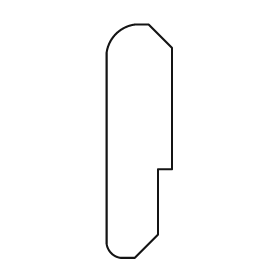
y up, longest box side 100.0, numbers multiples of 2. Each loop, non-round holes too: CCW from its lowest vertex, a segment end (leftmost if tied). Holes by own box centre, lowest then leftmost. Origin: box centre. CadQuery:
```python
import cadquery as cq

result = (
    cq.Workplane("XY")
    .moveTo(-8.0, -50.0)
    .lineTo(-2.0, -50.0)
    .lineTo(8.0, -40.0)
    .lineTo(8.0, -12.0)
    .lineTo(14.0, -12.0)
    .lineTo(14.0, 40.0)
    .lineTo(4.0, 50.0)
    .lineTo(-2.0, 50.0)
    .threePointArc((-10.0, 46.0), (-14.0, 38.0))
    .lineTo(-14.0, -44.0)
    .threePointArc((-12.0, -48.0), (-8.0, -50.0))
    .close()
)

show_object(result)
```